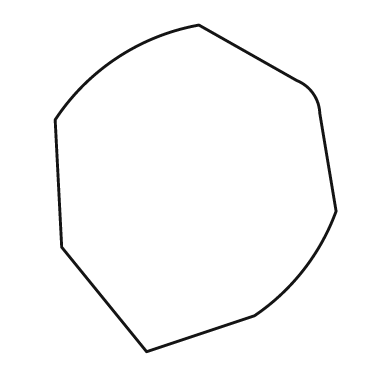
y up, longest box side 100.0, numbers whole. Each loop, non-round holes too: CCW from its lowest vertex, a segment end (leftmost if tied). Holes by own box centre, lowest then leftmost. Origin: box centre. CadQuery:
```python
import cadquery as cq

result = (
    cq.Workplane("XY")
    .moveTo(-15.0, -50.0)
    .lineTo(18.0, -39.0)
    .threePointArc((33.0, -25.0), (43.0, -7.0))
    .lineTo(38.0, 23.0)
    .threePointArc((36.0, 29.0), (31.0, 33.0))
    .lineTo(1.0, 50.0)
    .threePointArc((-24.0, 40.0), (-43.0, 21.0))
    .lineTo(-41.0, -18.0)
    .close()
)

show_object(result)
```